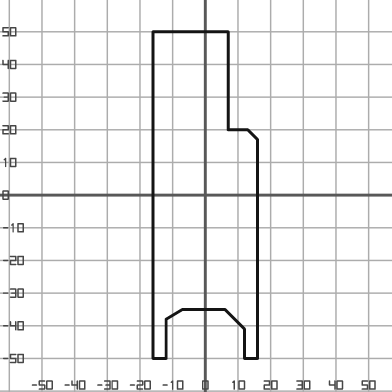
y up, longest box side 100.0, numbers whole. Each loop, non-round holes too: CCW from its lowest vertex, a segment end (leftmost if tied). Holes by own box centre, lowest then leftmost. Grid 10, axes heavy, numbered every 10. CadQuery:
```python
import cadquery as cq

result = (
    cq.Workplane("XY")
    .moveTo(-16.0, -50.0)
    .lineTo(-12.0, -50.0)
    .lineTo(-12.0, -38.0)
    .lineTo(-7.0, -35.0)
    .lineTo(6.0, -35.0)
    .lineTo(12.0, -41.0)
    .lineTo(12.0, -50.0)
    .lineTo(16.0, -50.0)
    .lineTo(16.0, 17.0)
    .lineTo(13.0, 20.0)
    .lineTo(7.0, 20.0)
    .lineTo(7.0, 50.0)
    .lineTo(-16.0, 50.0)
    .close()
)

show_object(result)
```